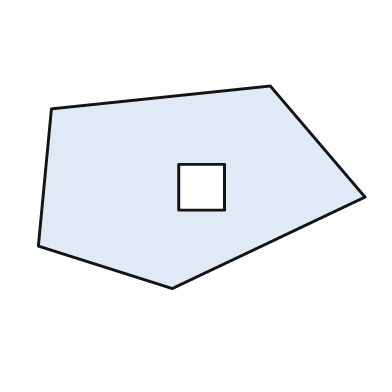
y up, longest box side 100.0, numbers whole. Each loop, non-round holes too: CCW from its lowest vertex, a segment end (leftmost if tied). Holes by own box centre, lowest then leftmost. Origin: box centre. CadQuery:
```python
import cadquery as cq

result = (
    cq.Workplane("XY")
    .moveTo(-9.0, -31.0)
    .lineTo(50.0, -3.0)
    .lineTo(21.0, 31.0)
    .lineTo(-46.0, 24.0)
    .lineTo(-50.0, -18.0)
    .close()
    .moveTo(-7.0, -7.0)
    .lineTo(7.0, -7.0)
    .lineTo(7.0, 7.0)
    .lineTo(-7.0, 7.0)
    .close()
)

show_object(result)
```